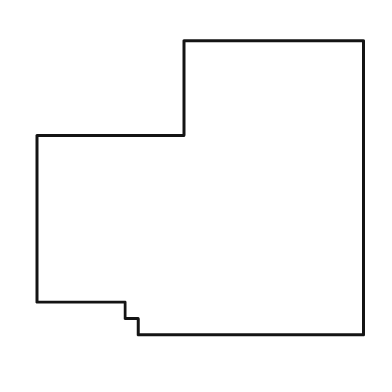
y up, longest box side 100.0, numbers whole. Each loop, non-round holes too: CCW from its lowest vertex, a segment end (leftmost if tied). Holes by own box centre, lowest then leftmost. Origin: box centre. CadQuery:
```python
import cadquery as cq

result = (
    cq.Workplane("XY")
    .moveTo(-19.0, -45.0)
    .lineTo(50.0, -45.0)
    .lineTo(50.0, 45.0)
    .lineTo(-5.0, 45.0)
    .lineTo(-5.0, 16.0)
    .lineTo(-50.0, 16.0)
    .lineTo(-50.0, -35.0)
    .lineTo(-23.0, -35.0)
    .lineTo(-23.0, -40.0)
    .lineTo(-19.0, -40.0)
    .close()
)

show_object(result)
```